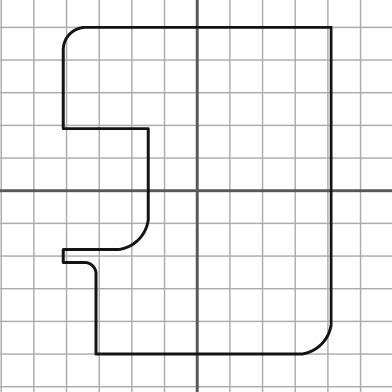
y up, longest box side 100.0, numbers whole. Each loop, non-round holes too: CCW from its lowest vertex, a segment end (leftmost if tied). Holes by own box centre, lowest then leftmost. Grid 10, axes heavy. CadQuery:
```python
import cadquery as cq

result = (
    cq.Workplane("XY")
    .moveTo(-31.0, -50.0)
    .lineTo(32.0, -50.0)
    .threePointArc((38.0, -47.0), (41.0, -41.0))
    .lineTo(41.0, 50.0)
    .lineTo(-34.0, 50.0)
    .threePointArc((-39.0, 48.0), (-41.0, 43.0))
    .lineTo(-41.0, 19.0)
    .lineTo(-15.0, 19.0)
    .lineTo(-15.0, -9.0)
    .threePointArc((-18.0, -15.0), (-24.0, -18.0))
    .lineTo(-41.0, -18.0)
    .lineTo(-41.0, -22.0)
    .lineTo(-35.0, -22.0)
    .threePointArc((-32.0, -23.0), (-31.0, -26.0))
    .close()
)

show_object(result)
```